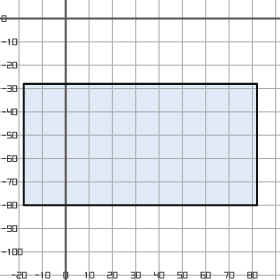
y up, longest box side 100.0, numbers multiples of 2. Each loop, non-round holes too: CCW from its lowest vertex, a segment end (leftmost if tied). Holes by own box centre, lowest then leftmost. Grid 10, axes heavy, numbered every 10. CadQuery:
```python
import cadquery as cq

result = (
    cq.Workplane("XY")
    .moveTo(-18.0, -80.0)
    .lineTo(82.0, -80.0)
    .lineTo(82.0, -28.0)
    .lineTo(-18.0, -28.0)
    .close()
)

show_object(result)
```